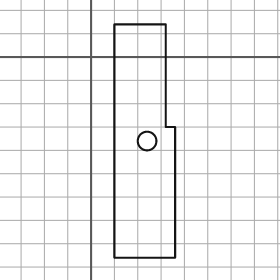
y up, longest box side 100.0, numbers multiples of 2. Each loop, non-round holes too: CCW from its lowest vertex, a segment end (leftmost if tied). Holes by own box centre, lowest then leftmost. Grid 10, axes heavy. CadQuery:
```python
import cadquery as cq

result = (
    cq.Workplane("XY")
    .moveTo(10.0, -86.0)
    .lineTo(36.0, -86.0)
    .lineTo(36.0, -30.0)
    .lineTo(32.0, -30.0)
    .lineTo(32.0, 14.0)
    .lineTo(10.0, 14.0)
    .close()
    .moveTo(24.0, -36.0)
    .circle(4.0)
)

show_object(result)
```